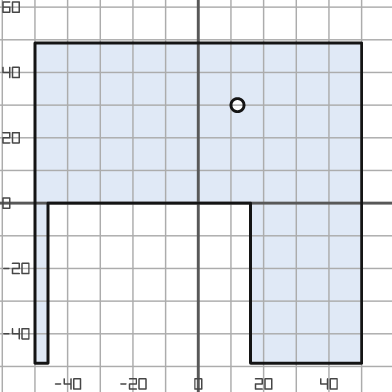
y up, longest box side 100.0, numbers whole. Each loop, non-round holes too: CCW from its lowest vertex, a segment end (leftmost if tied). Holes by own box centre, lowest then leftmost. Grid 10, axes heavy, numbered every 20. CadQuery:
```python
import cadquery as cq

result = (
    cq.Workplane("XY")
    .moveTo(-50.0, -49.0)
    .lineTo(-46.0, -49.0)
    .lineTo(-46.0, 0.0)
    .lineTo(16.0, 0.0)
    .lineTo(16.0, -49.0)
    .lineTo(50.0, -49.0)
    .lineTo(50.0, 49.0)
    .lineTo(-50.0, 49.0)
    .close()
    .moveTo(12.0, 30.0)
    .circle(2.0)
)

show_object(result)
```